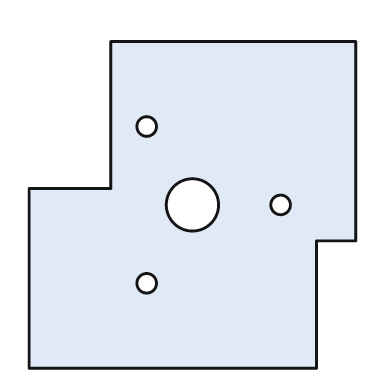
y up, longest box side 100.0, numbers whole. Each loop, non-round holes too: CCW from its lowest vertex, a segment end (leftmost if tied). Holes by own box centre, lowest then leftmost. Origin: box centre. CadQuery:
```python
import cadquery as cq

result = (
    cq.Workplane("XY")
    .moveTo(-50.0, -50.0)
    .lineTo(38.0, -50.0)
    .lineTo(38.0, -11.0)
    .lineTo(50.0, -11.0)
    .lineTo(50.0, 50.0)
    .lineTo(-25.0, 50.0)
    .lineTo(-25.0, 5.0)
    .lineTo(-50.0, 5.0)
    .close()
    .moveTo(-14.0, -24.0)
    .circle(3.0)
    .moveTo(0.0, 0.0)
    .circle(8.0)
    .moveTo(27.0, 0.0)
    .circle(3.0)
    .moveTo(-14.0, 24.0)
    .circle(3.0)
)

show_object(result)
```